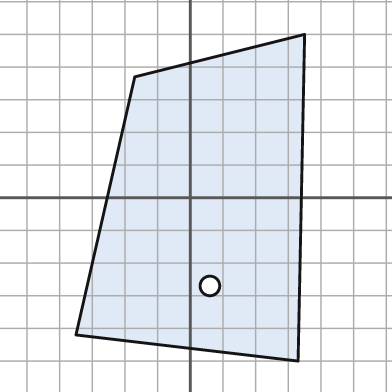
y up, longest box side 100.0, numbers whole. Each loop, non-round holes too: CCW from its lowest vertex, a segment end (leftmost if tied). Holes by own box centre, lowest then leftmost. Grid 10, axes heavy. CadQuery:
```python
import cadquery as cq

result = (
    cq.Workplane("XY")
    .moveTo(33.0, -50.0)
    .lineTo(35.0, 50.0)
    .lineTo(-17.0, 37.0)
    .lineTo(-35.0, -42.0)
    .close()
    .moveTo(6.0, -27.0)
    .circle(3.0)
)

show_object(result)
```